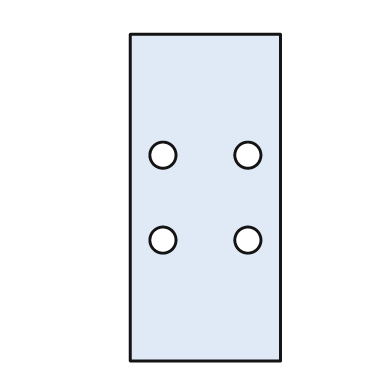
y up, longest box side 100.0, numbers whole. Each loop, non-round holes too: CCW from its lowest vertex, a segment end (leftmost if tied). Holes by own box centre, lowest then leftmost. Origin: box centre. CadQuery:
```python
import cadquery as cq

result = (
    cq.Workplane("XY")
    .moveTo(-23.0, -50.0)
    .lineTo(23.0, -50.0)
    .lineTo(23.0, 50.0)
    .lineTo(-23.0, 50.0)
    .close()
    .moveTo(-13.0, -13.0)
    .circle(4.0)
    .moveTo(13.0, -13.0)
    .circle(4.0)
    .moveTo(-13.0, 13.0)
    .circle(4.0)
    .moveTo(13.0, 13.0)
    .circle(4.0)
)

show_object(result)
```